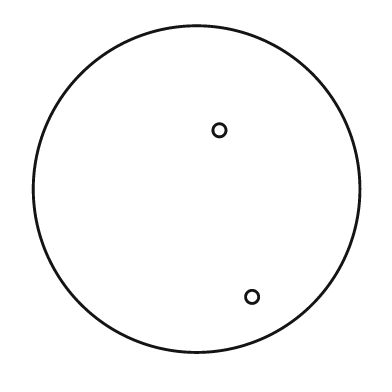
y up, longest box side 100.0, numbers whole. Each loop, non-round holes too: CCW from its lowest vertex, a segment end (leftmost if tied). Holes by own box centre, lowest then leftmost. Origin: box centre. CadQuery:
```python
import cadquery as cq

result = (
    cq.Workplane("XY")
    .moveTo(0.0, 0.0)
    .circle(50.0)
    .moveTo(17.0, -33.0)
    .circle(2.0)
    .moveTo(7.0, 18.0)
    .circle(2.0)
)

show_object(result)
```